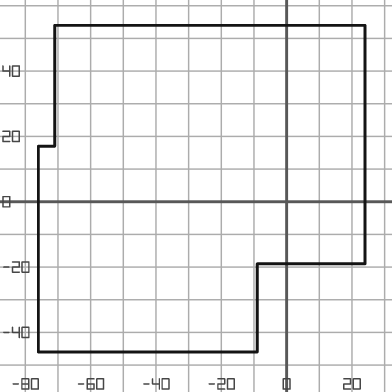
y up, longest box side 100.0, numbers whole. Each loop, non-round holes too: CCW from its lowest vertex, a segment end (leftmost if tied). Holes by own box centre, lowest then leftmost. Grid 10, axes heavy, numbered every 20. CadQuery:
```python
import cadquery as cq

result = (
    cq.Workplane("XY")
    .moveTo(-76.0, -46.0)
    .lineTo(-9.0, -46.0)
    .lineTo(-9.0, -19.0)
    .lineTo(24.0, -19.0)
    .lineTo(24.0, 54.0)
    .lineTo(-71.0, 54.0)
    .lineTo(-71.0, 17.0)
    .lineTo(-76.0, 17.0)
    .close()
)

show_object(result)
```